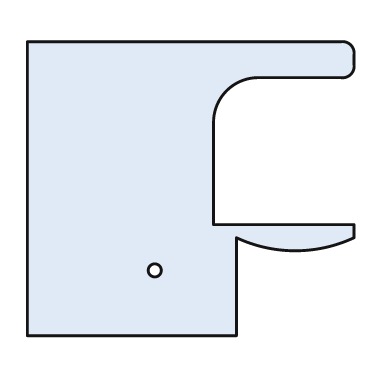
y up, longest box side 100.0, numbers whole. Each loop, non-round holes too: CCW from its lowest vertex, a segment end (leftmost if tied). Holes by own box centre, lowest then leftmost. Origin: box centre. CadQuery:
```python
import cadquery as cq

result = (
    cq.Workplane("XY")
    .moveTo(-50.0, -45.0)
    .lineTo(14.0, -45.0)
    .lineTo(14.0, -15.0)
    .threePointArc((32.0, -19.0), (50.0, -15.0))
    .lineTo(50.0, -11.0)
    .lineTo(7.0, -11.0)
    .lineTo(7.0, 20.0)
    .threePointArc((11.0, 30.0), (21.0, 34.0))
    .lineTo(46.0, 34.0)
    .threePointArc((49.0, 35.0), (50.0, 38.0))
    .lineTo(50.0, 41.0)
    .threePointArc((49.0, 44.0), (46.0, 45.0))
    .lineTo(-50.0, 45.0)
    .close()
    .moveTo(-11.0, -25.0)
    .circle(2.0)
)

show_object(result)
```